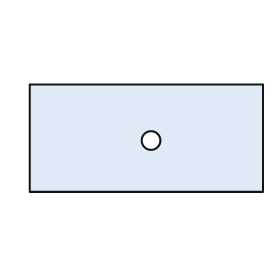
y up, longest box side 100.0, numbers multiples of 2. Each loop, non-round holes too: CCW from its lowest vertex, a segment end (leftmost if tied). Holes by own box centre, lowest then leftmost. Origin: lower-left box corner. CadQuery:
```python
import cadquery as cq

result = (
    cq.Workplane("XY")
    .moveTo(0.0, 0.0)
    .lineTo(100.0, 0.0)
    .lineTo(100.0, 46.0)
    .lineTo(0.0, 46.0)
    .close()
    .moveTo(52.0, 22.0)
    .circle(4.0)
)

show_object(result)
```